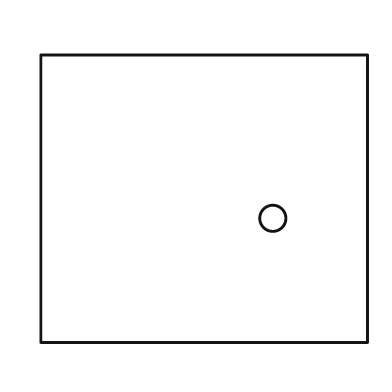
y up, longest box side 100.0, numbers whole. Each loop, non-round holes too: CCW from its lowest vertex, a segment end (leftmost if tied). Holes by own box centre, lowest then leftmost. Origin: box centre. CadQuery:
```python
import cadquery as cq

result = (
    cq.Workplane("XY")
    .moveTo(-50.0, -44.0)
    .lineTo(50.0, -44.0)
    .lineTo(50.0, 44.0)
    .lineTo(-50.0, 44.0)
    .close()
    .moveTo(21.0, -6.0)
    .circle(4.0)
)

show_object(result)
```